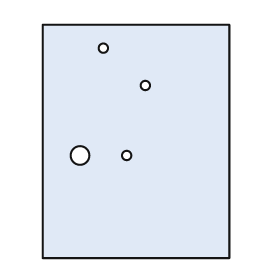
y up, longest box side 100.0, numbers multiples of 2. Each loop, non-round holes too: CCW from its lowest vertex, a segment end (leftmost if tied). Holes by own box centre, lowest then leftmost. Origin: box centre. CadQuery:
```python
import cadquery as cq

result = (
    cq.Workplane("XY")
    .moveTo(-40.0, -50.0)
    .lineTo(40.0, -50.0)
    .lineTo(40.0, 50.0)
    .lineTo(-40.0, 50.0)
    .close()
    .moveTo(-24.0, -6.0)
    .circle(4.0)
    .moveTo(-4.0, -6.0)
    .circle(2.0)
    .moveTo(4.0, 24.0)
    .circle(2.0)
    .moveTo(-14.0, 40.0)
    .circle(2.0)
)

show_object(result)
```